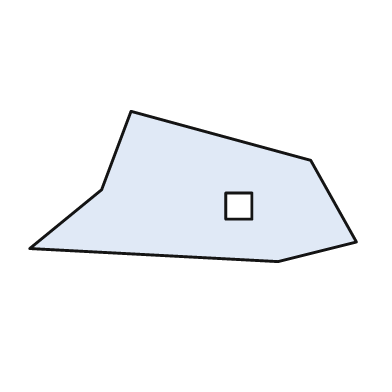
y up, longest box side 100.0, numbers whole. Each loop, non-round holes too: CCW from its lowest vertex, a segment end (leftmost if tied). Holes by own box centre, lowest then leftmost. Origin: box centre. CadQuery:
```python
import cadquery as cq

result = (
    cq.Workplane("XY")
    .moveTo(26.0, -23.0)
    .lineTo(50.0, -17.0)
    .lineTo(36.0, 8.0)
    .lineTo(-19.0, 23.0)
    .lineTo(-28.0, -1.0)
    .lineTo(-50.0, -19.0)
    .close()
    .moveTo(10.0, -10.0)
    .lineTo(18.0, -10.0)
    .lineTo(18.0, -2.0)
    .lineTo(10.0, -2.0)
    .close()
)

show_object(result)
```